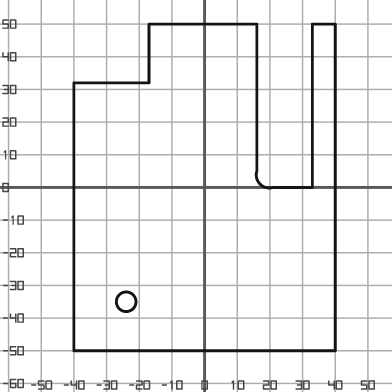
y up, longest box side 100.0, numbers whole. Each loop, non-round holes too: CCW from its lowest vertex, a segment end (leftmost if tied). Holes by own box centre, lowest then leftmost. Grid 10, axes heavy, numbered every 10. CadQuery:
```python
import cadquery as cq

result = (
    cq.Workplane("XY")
    .moveTo(-40.0, -50.0)
    .lineTo(40.0, -50.0)
    .lineTo(40.0, 50.0)
    .lineTo(33.0, 50.0)
    .lineTo(33.0, 0.0)
    .lineTo(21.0, 0.0)
    .threePointArc((17.0, 1.0), (16.0, 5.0))
    .lineTo(16.0, 50.0)
    .lineTo(-17.0, 50.0)
    .lineTo(-17.0, 32.0)
    .lineTo(-40.0, 32.0)
    .close()
    .moveTo(-24.0, -35.0)
    .circle(3.0)
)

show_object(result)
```